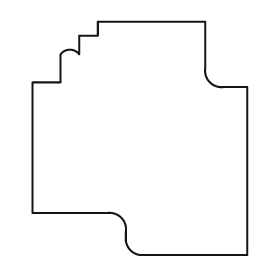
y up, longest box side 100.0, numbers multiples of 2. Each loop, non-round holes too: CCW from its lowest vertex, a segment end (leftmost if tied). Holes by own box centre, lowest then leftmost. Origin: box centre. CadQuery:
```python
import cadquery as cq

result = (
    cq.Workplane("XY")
    .moveTo(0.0, -50.0)
    .lineTo(46.0, -50.0)
    .lineTo(46.0, 22.0)
    .lineTo(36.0, 22.0)
    .threePointArc((30.0, 24.0), (28.0, 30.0))
    .lineTo(28.0, 50.0)
    .lineTo(-18.0, 50.0)
    .lineTo(-18.0, 44.0)
    .lineTo(-26.0, 44.0)
    .lineTo(-26.0, 36.0)
    .threePointArc((-30.0, 38.0), (-34.0, 36.0))
    .lineTo(-34.0, 24.0)
    .lineTo(-46.0, 24.0)
    .lineTo(-46.0, -32.0)
    .lineTo(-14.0, -32.0)
    .threePointArc((-8.0, -34.0), (-6.0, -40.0))
    .lineTo(-6.0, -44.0)
    .threePointArc((-4.0, -48.0), (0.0, -50.0))
    .close()
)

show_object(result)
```